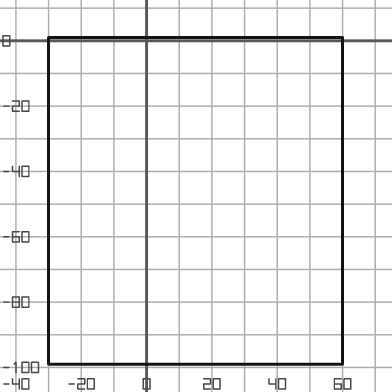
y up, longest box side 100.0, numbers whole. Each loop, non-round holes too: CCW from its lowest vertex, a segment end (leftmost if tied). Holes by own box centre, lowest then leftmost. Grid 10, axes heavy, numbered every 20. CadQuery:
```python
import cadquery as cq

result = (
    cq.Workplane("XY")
    .moveTo(-30.0, -99.0)
    .lineTo(60.0, -99.0)
    .lineTo(60.0, 1.0)
    .lineTo(-30.0, 1.0)
    .close()
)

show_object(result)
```